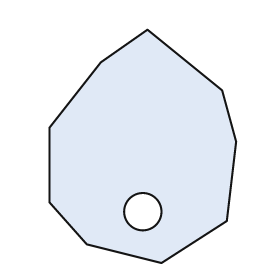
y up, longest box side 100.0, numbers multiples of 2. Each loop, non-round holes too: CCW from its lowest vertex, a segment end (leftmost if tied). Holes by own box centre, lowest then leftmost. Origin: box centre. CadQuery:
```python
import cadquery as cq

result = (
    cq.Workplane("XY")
    .moveTo(8.0, -50.0)
    .lineTo(36.0, -32.0)
    .lineTo(40.0, 2.0)
    .lineTo(34.0, 24.0)
    .lineTo(2.0, 50.0)
    .lineTo(-18.0, 36.0)
    .lineTo(-40.0, 8.0)
    .lineTo(-40.0, -24.0)
    .lineTo(-24.0, -42.0)
    .close()
    .moveTo(0.0, -28.0)
    .circle(8.0)
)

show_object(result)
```